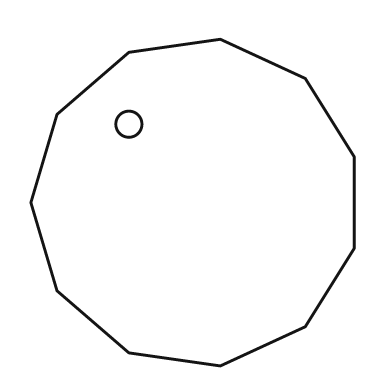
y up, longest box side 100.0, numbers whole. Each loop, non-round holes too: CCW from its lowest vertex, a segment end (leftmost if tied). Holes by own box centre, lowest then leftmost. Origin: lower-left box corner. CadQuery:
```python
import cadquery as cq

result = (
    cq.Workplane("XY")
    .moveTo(58.0, 0.0)
    .lineTo(84.0, 12.0)
    .lineTo(99.0, 36.0)
    .lineTo(99.0, 64.0)
    .lineTo(84.0, 88.0)
    .lineTo(58.0, 100.0)
    .lineTo(30.0, 96.0)
    .lineTo(8.0, 77.0)
    .lineTo(0.0, 50.0)
    .lineTo(8.0, 23.0)
    .lineTo(30.0, 4.0)
    .close()
    .moveTo(30.0, 74.0)
    .circle(4.0)
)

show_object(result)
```